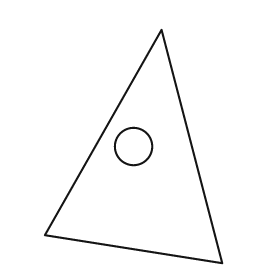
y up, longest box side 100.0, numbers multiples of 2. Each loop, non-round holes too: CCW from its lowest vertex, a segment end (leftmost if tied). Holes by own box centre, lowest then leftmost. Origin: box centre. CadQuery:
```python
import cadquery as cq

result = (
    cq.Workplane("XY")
    .moveTo(38.0, -50.0)
    .lineTo(12.0, 50.0)
    .lineTo(-38.0, -38.0)
    .close()
    .moveTo(0.0, 0.0)
    .circle(8.0)
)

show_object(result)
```